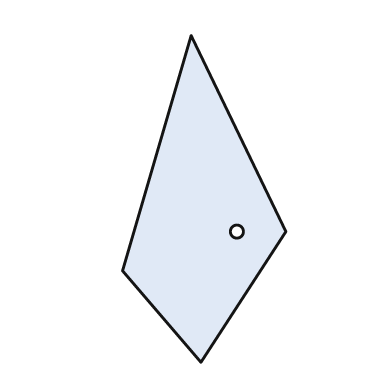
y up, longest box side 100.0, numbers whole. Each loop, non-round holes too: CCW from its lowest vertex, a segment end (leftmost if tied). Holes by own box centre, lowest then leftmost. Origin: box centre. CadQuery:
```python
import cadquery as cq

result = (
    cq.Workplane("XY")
    .moveTo(-1.0, -50.0)
    .lineTo(25.0, -10.0)
    .lineTo(-4.0, 50.0)
    .lineTo(-25.0, -22.0)
    .close()
    .moveTo(10.0, -10.0)
    .circle(2.0)
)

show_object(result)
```